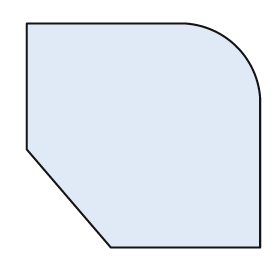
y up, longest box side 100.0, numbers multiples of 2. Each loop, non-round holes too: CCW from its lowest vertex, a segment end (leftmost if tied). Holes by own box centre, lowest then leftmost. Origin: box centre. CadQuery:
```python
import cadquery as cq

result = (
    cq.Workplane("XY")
    .moveTo(-14.0, -48.0)
    .lineTo(50.0, -48.0)
    .lineTo(50.0, 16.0)
    .threePointArc((40.0, 38.0), (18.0, 48.0))
    .lineTo(-50.0, 48.0)
    .lineTo(-50.0, -6.0)
    .close()
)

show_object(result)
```